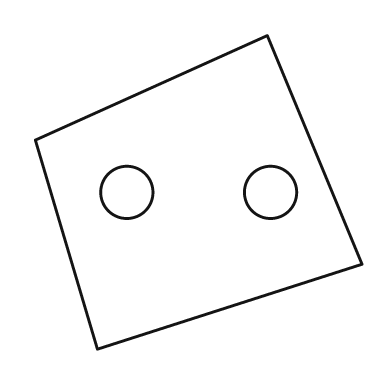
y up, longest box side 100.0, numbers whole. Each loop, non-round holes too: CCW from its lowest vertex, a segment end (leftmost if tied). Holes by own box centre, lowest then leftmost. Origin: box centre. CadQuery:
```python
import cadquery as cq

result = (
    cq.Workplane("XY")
    .moveTo(-31.0, -48.0)
    .lineTo(50.0, -22.0)
    .lineTo(21.0, 48.0)
    .lineTo(-50.0, 16.0)
    .close()
    .moveTo(-22.0, 0.0)
    .circle(8.0)
    .moveTo(22.0, 0.0)
    .circle(8.0)
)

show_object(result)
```